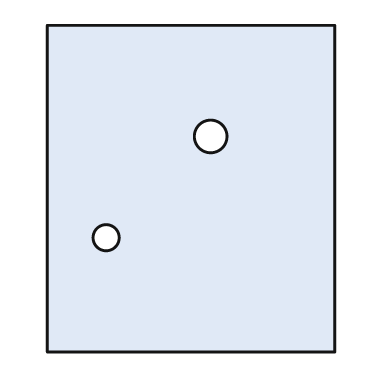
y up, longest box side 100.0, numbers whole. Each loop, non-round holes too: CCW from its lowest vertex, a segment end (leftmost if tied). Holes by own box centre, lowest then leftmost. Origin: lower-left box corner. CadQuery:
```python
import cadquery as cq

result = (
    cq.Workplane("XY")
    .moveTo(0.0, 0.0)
    .lineTo(88.0, 0.0)
    .lineTo(88.0, 100.0)
    .lineTo(0.0, 100.0)
    .close()
    .moveTo(18.0, 35.0)
    .circle(4.0)
    .moveTo(50.0, 66.0)
    .circle(5.0)
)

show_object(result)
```